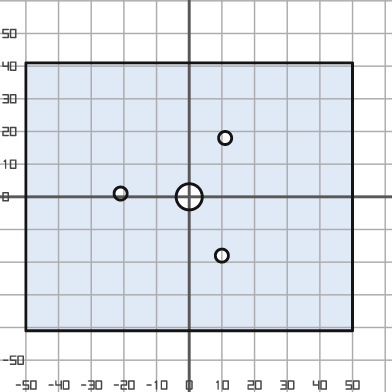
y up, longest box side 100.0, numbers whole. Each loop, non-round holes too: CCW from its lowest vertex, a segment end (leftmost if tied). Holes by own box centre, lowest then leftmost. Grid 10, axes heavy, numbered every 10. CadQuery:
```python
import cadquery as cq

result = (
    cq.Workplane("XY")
    .moveTo(-50.0, -41.0)
    .lineTo(50.0, -41.0)
    .lineTo(50.0, 41.0)
    .lineTo(-50.0, 41.0)
    .close()
    .moveTo(10.0, -18.0)
    .circle(2.0)
    .moveTo(0.0, 0.0)
    .circle(4.0)
    .moveTo(-21.0, 1.0)
    .circle(2.0)
    .moveTo(11.0, 18.0)
    .circle(2.0)
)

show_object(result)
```